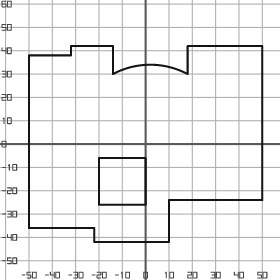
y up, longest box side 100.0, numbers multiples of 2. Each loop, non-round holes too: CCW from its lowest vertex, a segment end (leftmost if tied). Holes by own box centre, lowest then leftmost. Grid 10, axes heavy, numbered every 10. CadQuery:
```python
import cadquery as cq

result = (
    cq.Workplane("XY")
    .moveTo(-22.0, -42.0)
    .lineTo(10.0, -42.0)
    .lineTo(10.0, -24.0)
    .lineTo(50.0, -24.0)
    .lineTo(50.0, 42.0)
    .lineTo(18.0, 42.0)
    .lineTo(18.0, 30.0)
    .threePointArc((2.0, 34.0), (-14.0, 30.0))
    .lineTo(-14.0, 42.0)
    .lineTo(-32.0, 42.0)
    .lineTo(-32.0, 38.0)
    .lineTo(-50.0, 38.0)
    .lineTo(-50.0, -36.0)
    .lineTo(-22.0, -36.0)
    .close()
    .moveTo(-20.0, -26.0)
    .lineTo(0.0, -26.0)
    .lineTo(0.0, -6.0)
    .lineTo(-20.0, -6.0)
    .close()
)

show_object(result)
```